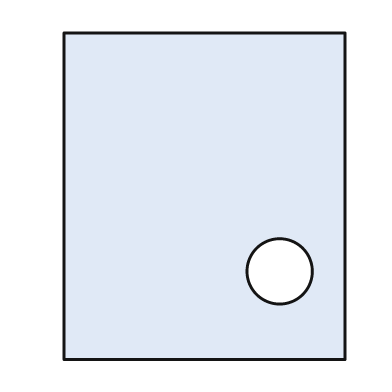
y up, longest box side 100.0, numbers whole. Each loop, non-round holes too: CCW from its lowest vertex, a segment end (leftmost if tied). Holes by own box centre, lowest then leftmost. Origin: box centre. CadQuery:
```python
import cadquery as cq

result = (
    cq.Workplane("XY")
    .moveTo(-43.0, -50.0)
    .lineTo(43.0, -50.0)
    .lineTo(43.0, 50.0)
    .lineTo(-43.0, 50.0)
    .close()
    .moveTo(23.0, -23.0)
    .circle(10.0)
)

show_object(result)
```